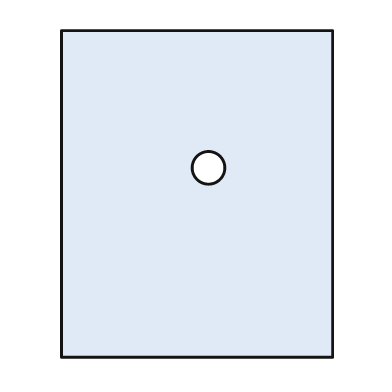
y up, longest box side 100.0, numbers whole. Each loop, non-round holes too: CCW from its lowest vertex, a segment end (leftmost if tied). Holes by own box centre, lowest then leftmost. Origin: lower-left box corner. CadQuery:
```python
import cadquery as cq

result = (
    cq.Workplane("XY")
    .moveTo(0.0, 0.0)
    .lineTo(83.0, 0.0)
    .lineTo(83.0, 100.0)
    .lineTo(0.0, 100.0)
    .close()
    .moveTo(45.0, 58.0)
    .circle(5.0)
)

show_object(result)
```